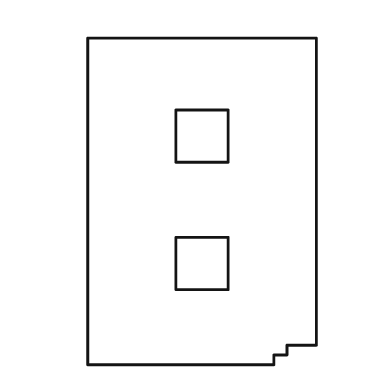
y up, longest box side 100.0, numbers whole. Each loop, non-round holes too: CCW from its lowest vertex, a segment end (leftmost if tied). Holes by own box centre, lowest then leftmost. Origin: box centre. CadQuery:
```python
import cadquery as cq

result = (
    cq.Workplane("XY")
    .moveTo(-35.0, -50.0)
    .lineTo(22.0, -50.0)
    .lineTo(22.0, -47.0)
    .lineTo(26.0, -47.0)
    .lineTo(26.0, -44.0)
    .lineTo(35.0, -44.0)
    .lineTo(35.0, 50.0)
    .lineTo(-35.0, 50.0)
    .close()
    .moveTo(-8.0, -27.0)
    .lineTo(8.0, -27.0)
    .lineTo(8.0, -11.0)
    .lineTo(-8.0, -11.0)
    .close()
    .moveTo(-8.0, 12.0)
    .lineTo(8.0, 12.0)
    .lineTo(8.0, 28.0)
    .lineTo(-8.0, 28.0)
    .close()
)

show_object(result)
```